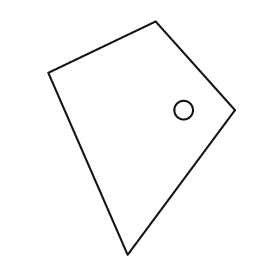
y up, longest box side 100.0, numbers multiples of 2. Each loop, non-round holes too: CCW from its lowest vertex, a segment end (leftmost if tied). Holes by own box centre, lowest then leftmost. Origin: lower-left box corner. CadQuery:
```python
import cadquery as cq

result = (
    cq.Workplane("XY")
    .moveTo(34.0, 0.0)
    .lineTo(80.0, 62.0)
    .lineTo(46.0, 100.0)
    .lineTo(0.0, 78.0)
    .close()
    .moveTo(58.0, 62.0)
    .circle(4.0)
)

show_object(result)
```